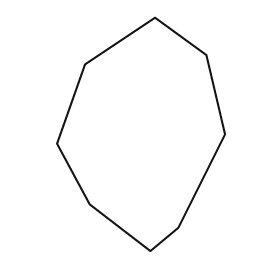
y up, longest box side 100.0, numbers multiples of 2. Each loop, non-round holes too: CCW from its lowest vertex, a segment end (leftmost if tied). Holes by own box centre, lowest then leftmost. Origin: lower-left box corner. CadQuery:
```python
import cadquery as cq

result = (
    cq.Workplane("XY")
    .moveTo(40.0, 0.0)
    .lineTo(52.0, 10.0)
    .lineTo(72.0, 50.0)
    .lineTo(64.0, 84.0)
    .lineTo(42.0, 100.0)
    .lineTo(12.0, 80.0)
    .lineTo(0.0, 46.0)
    .lineTo(14.0, 20.0)
    .close()
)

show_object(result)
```